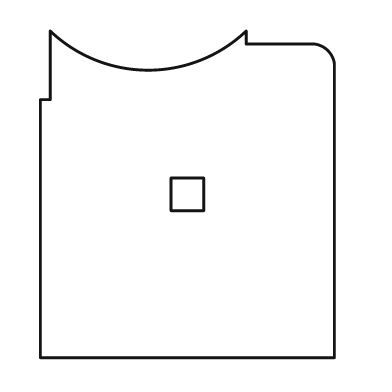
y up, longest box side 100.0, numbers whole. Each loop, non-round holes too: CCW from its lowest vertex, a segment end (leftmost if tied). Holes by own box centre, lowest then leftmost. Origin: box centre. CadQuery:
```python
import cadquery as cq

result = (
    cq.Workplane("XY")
    .moveTo(-45.0, -50.0)
    .lineTo(45.0, -50.0)
    .lineTo(45.0, 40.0)
    .threePointArc((43.0, 44.0), (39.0, 46.0))
    .lineTo(18.0, 46.0)
    .lineTo(18.0, 50.0)
    .threePointArc((-12.0, 38.0), (-42.0, 50.0))
    .lineTo(-42.0, 29.0)
    .lineTo(-45.0, 29.0)
    .close()
    .moveTo(-5.0, -5.0)
    .lineTo(5.0, -5.0)
    .lineTo(5.0, 5.0)
    .lineTo(-5.0, 5.0)
    .close()
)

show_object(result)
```